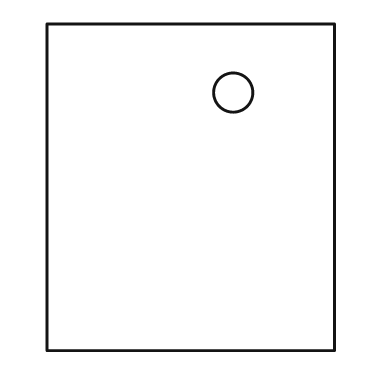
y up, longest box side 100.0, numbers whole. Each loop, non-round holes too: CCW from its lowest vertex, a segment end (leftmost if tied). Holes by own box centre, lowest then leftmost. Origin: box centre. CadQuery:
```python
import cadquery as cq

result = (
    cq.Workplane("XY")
    .moveTo(-44.0, -50.0)
    .lineTo(44.0, -50.0)
    .lineTo(44.0, 50.0)
    .lineTo(-44.0, 50.0)
    .close()
    .moveTo(13.0, 29.0)
    .circle(6.0)
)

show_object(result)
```